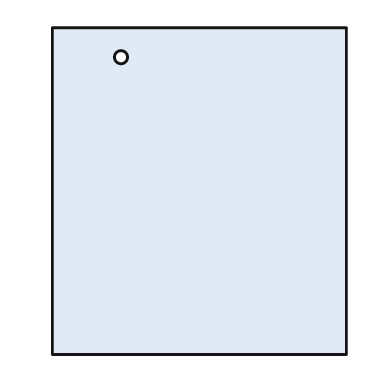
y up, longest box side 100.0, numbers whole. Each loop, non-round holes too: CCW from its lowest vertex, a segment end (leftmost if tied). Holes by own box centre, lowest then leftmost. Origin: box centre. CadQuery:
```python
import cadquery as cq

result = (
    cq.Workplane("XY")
    .moveTo(-45.0, -50.0)
    .lineTo(45.0, -50.0)
    .lineTo(45.0, 50.0)
    .lineTo(-45.0, 50.0)
    .close()
    .moveTo(-24.0, 41.0)
    .circle(2.0)
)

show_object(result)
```